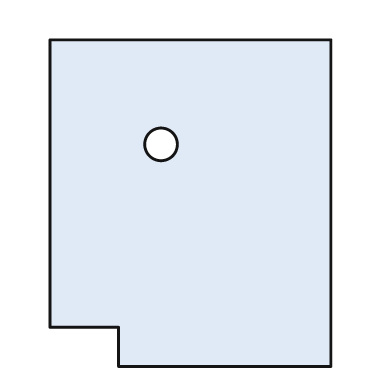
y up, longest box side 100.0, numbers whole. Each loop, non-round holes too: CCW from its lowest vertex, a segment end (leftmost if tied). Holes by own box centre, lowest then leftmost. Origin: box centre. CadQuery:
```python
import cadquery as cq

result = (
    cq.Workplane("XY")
    .moveTo(-22.0, -50.0)
    .lineTo(43.0, -50.0)
    .lineTo(43.0, 50.0)
    .lineTo(-43.0, 50.0)
    .lineTo(-43.0, -38.0)
    .lineTo(-22.0, -38.0)
    .close()
    .moveTo(-9.0, 18.0)
    .circle(5.0)
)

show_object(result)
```